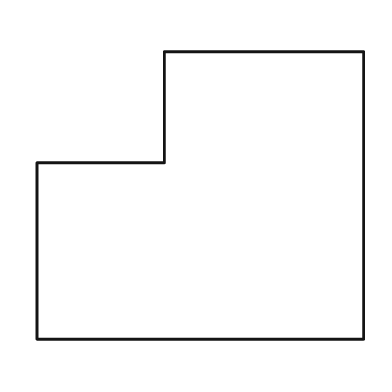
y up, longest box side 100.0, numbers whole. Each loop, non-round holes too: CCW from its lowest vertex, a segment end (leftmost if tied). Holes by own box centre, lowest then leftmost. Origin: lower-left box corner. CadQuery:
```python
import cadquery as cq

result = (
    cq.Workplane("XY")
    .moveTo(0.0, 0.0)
    .lineTo(100.0, 0.0)
    .lineTo(100.0, 88.0)
    .lineTo(39.0, 88.0)
    .lineTo(39.0, 54.0)
    .lineTo(0.0, 54.0)
    .close()
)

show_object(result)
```